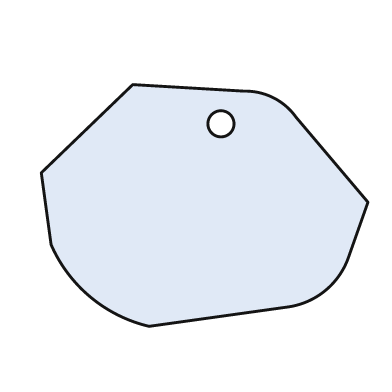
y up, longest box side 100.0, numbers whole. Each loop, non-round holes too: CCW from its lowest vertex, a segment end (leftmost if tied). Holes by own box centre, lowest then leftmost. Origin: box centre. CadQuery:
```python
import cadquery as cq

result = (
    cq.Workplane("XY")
    .moveTo(-17.0, -37.0)
    .lineTo(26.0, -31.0)
    .threePointArc((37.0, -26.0), (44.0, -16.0))
    .lineTo(50.0, 1.0)
    .lineTo(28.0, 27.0)
    .threePointArc((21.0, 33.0), (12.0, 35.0))
    .lineTo(-22.0, 37.0)
    .lineTo(-50.0, 10.0)
    .lineTo(-47.0, -12.0)
    .threePointArc((-35.0, -28.0), (-17.0, -37.0))
    .close()
    .moveTo(5.0, 25.0)
    .circle(4.0)
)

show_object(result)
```